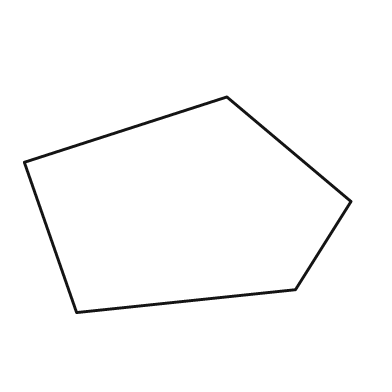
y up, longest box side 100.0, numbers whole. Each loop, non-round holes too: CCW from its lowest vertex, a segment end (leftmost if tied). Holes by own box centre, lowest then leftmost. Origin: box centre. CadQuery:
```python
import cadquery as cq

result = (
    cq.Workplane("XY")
    .moveTo(-34.0, -33.0)
    .lineTo(33.0, -26.0)
    .lineTo(50.0, 1.0)
    .lineTo(12.0, 33.0)
    .lineTo(-50.0, 13.0)
    .close()
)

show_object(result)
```